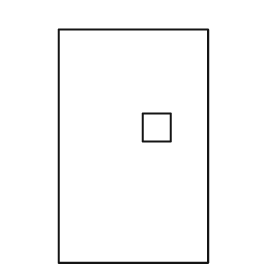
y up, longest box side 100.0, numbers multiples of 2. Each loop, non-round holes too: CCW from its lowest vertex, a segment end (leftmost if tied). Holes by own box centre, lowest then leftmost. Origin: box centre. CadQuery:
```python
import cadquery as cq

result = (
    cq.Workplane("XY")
    .moveTo(-32.0, -50.0)
    .lineTo(32.0, -50.0)
    .lineTo(32.0, 50.0)
    .lineTo(-32.0, 50.0)
    .close()
    .moveTo(4.0, 2.0)
    .lineTo(16.0, 2.0)
    .lineTo(16.0, 14.0)
    .lineTo(4.0, 14.0)
    .close()
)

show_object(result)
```